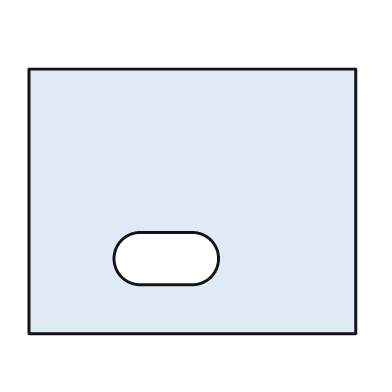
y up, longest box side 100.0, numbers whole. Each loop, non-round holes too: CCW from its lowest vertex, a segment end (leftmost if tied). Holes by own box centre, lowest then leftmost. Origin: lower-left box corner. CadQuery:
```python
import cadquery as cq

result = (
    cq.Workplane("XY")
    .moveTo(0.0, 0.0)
    .lineTo(100.0, 0.0)
    .lineTo(100.0, 81.0)
    .lineTo(0.0, 81.0)
    .close()
    .moveTo(34.0, 15.0)
    .lineTo(50.0, 15.0)
    .threePointArc((58.0, 23.0), (50.0, 31.0))
    .lineTo(34.0, 31.0)
    .threePointArc((26.0, 23.0), (34.0, 15.0))
    .close()
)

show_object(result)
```